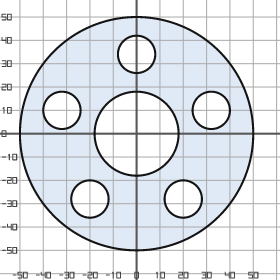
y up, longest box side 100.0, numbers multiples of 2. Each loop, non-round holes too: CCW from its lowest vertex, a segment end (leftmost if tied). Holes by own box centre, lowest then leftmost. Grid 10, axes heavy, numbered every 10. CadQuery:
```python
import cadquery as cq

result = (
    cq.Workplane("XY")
    .moveTo(0.0, 0.0)
    .circle(50.0)
    .moveTo(-20.0, -28.0)
    .circle(8.0)
    .moveTo(20.0, -28.0)
    .circle(8.0)
    .moveTo(0.0, 0.0)
    .circle(18.0)
    .moveTo(-32.0, 10.0)
    .circle(8.0)
    .moveTo(32.0, 10.0)
    .circle(8.0)
    .moveTo(0.0, 34.0)
    .circle(8.0)
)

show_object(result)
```